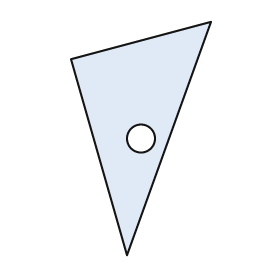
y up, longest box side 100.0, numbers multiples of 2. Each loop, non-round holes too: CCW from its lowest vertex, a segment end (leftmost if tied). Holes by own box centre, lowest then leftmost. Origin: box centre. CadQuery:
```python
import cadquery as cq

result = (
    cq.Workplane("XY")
    .moveTo(-6.0, -50.0)
    .lineTo(30.0, 50.0)
    .lineTo(-30.0, 34.0)
    .close()
    .moveTo(0.0, 0.0)
    .circle(6.0)
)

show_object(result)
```